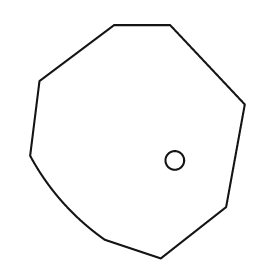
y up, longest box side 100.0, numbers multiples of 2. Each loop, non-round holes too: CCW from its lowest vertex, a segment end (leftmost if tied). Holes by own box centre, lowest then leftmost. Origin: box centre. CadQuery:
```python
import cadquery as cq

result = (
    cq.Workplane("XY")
    .moveTo(10.0, -50.0)
    .lineTo(38.0, -28.0)
    .lineTo(46.0, 16.0)
    .lineTo(14.0, 50.0)
    .lineTo(-10.0, 50.0)
    .lineTo(-42.0, 26.0)
    .lineTo(-46.0, -6.0)
    .threePointArc((-32.0, -26.0), (-14.0, -42.0))
    .close()
    .moveTo(16.0, -8.0)
    .circle(4.0)
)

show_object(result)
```